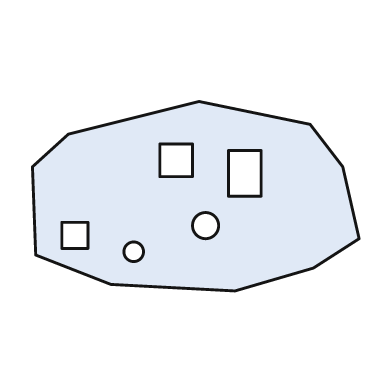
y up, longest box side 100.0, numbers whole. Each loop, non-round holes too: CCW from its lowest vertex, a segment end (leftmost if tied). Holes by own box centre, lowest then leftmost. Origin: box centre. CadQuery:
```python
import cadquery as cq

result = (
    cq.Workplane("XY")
    .moveTo(12.0, -29.0)
    .lineTo(36.0, -22.0)
    .lineTo(50.0, -13.0)
    .lineTo(45.0, 9.0)
    .lineTo(35.0, 22.0)
    .lineTo(1.0, 29.0)
    .lineTo(-39.0, 19.0)
    .lineTo(-50.0, 9.0)
    .lineTo(-49.0, -18.0)
    .lineTo(-26.0, -27.0)
    .close()
    .moveTo(-19.0, -17.0)
    .circle(3.0)
    .moveTo(-41.0, -16.0)
    .lineTo(-33.0, -16.0)
    .lineTo(-33.0, -8.0)
    .lineTo(-41.0, -8.0)
    .close()
    .moveTo(3.0, -9.0)
    .circle(4.0)
    .moveTo(10.0, 0.0)
    .lineTo(20.0, 0.0)
    .lineTo(20.0, 14.0)
    .lineTo(10.0, 14.0)
    .close()
    .moveTo(-11.0, 6.0)
    .lineTo(-1.0, 6.0)
    .lineTo(-1.0, 16.0)
    .lineTo(-11.0, 16.0)
    .close()
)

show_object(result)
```